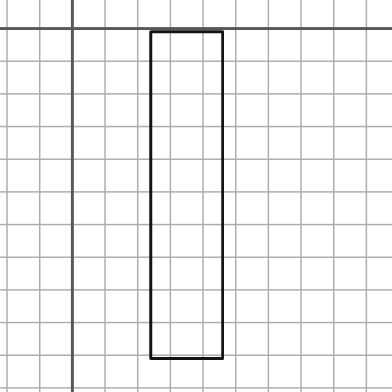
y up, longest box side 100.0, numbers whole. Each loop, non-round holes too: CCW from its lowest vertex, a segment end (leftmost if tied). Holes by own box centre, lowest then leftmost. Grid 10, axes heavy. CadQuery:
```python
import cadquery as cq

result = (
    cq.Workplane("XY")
    .moveTo(24.0, -101.0)
    .lineTo(46.0, -101.0)
    .lineTo(46.0, -1.0)
    .lineTo(24.0, -1.0)
    .close()
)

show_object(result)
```